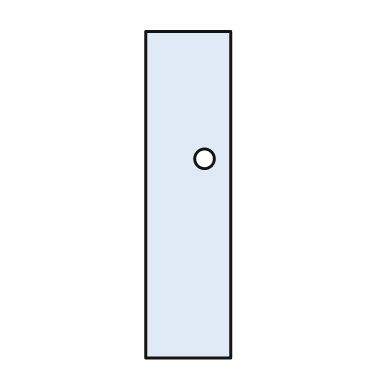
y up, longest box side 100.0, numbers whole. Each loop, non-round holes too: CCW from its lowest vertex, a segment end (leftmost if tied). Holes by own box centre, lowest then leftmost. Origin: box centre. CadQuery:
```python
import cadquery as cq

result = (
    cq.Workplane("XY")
    .moveTo(-13.0, -50.0)
    .lineTo(13.0, -50.0)
    .lineTo(13.0, 50.0)
    .lineTo(-13.0, 50.0)
    .close()
    .moveTo(5.0, 11.0)
    .circle(3.0)
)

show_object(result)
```